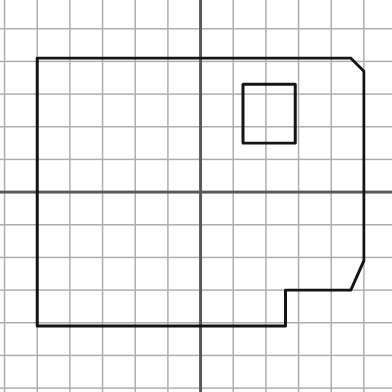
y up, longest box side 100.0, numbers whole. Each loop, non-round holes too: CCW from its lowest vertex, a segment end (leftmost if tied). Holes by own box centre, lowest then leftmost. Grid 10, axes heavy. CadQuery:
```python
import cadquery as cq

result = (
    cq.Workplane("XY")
    .moveTo(-50.0, -41.0)
    .lineTo(26.0, -41.0)
    .lineTo(26.0, -30.0)
    .lineTo(46.0, -30.0)
    .lineTo(50.0, -21.0)
    .lineTo(50.0, 37.0)
    .lineTo(46.0, 41.0)
    .lineTo(-50.0, 41.0)
    .close()
    .moveTo(13.0, 15.0)
    .lineTo(29.0, 15.0)
    .lineTo(29.0, 33.0)
    .lineTo(13.0, 33.0)
    .close()
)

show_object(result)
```